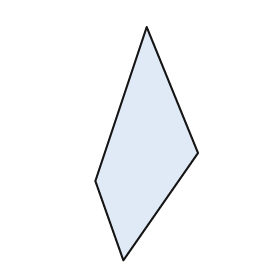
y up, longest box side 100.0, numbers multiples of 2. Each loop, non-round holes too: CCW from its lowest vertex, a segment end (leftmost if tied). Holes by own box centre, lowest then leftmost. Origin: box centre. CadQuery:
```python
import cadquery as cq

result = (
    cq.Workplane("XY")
    .moveTo(-10.0, -50.0)
    .lineTo(22.0, -4.0)
    .lineTo(0.0, 50.0)
    .lineTo(-22.0, -16.0)
    .close()
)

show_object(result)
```